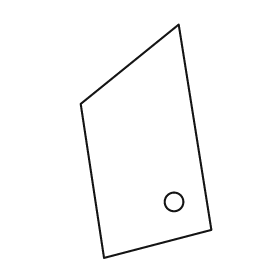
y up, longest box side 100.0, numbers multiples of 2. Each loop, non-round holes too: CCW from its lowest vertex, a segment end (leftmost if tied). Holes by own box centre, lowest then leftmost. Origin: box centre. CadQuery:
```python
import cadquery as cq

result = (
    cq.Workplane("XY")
    .moveTo(-18.0, -50.0)
    .lineTo(28.0, -38.0)
    .lineTo(14.0, 50.0)
    .lineTo(-28.0, 16.0)
    .close()
    .moveTo(12.0, -26.0)
    .circle(4.0)
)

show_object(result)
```